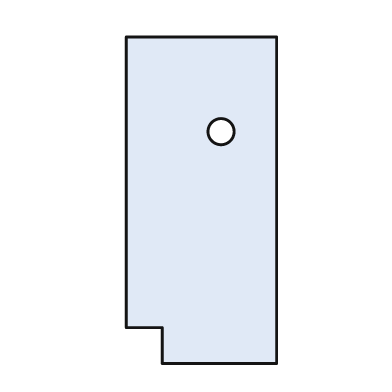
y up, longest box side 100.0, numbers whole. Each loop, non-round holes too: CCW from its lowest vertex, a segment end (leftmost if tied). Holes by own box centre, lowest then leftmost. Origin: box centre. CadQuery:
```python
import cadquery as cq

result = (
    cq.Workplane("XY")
    .moveTo(-12.0, -50.0)
    .lineTo(23.0, -50.0)
    .lineTo(23.0, 50.0)
    .lineTo(-23.0, 50.0)
    .lineTo(-23.0, -39.0)
    .lineTo(-12.0, -39.0)
    .close()
    .moveTo(6.0, 21.0)
    .circle(4.0)
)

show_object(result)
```